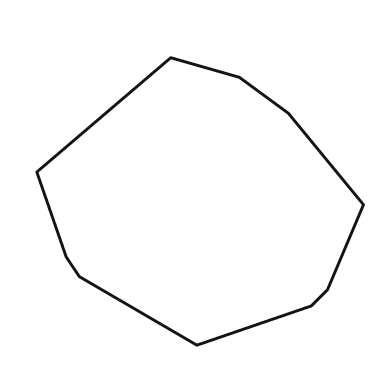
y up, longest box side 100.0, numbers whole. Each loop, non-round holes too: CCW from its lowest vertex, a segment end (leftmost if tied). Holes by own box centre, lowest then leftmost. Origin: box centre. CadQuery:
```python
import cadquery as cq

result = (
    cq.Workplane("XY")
    .moveTo(-1.0, -44.0)
    .lineTo(34.0, -32.0)
    .lineTo(39.0, -27.0)
    .lineTo(50.0, -1.0)
    .lineTo(27.0, 27.0)
    .lineTo(12.0, 38.0)
    .lineTo(-9.0, 44.0)
    .lineTo(-50.0, 9.0)
    .lineTo(-41.0, -17.0)
    .lineTo(-37.0, -23.0)
    .close()
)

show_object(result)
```